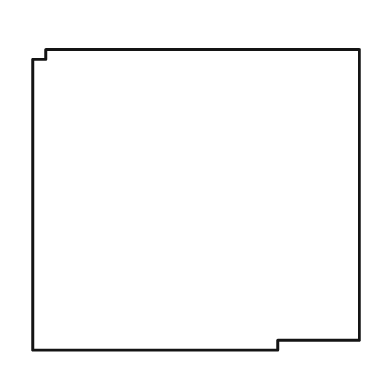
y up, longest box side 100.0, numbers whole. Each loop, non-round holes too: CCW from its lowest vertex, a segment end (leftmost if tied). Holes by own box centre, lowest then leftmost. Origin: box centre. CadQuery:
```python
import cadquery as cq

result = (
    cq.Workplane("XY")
    .moveTo(-50.0, -46.0)
    .lineTo(25.0, -46.0)
    .lineTo(25.0, -43.0)
    .lineTo(50.0, -43.0)
    .lineTo(50.0, 46.0)
    .lineTo(-46.0, 46.0)
    .lineTo(-46.0, 43.0)
    .lineTo(-50.0, 43.0)
    .close()
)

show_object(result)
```